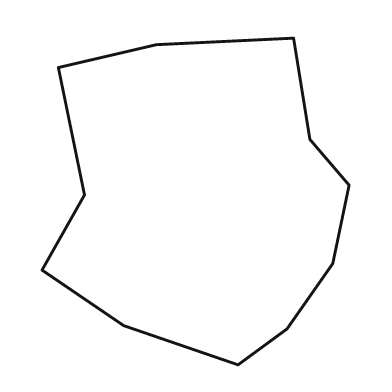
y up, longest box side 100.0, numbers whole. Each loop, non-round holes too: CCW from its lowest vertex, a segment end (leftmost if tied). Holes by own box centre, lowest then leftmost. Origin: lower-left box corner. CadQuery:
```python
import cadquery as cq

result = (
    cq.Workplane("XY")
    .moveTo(60.0, 0.0)
    .lineTo(75.0, 11.0)
    .lineTo(89.0, 31.0)
    .lineTo(94.0, 55.0)
    .lineTo(82.0, 69.0)
    .lineTo(77.0, 100.0)
    .lineTo(35.0, 98.0)
    .lineTo(5.0, 91.0)
    .lineTo(13.0, 52.0)
    .lineTo(0.0, 29.0)
    .lineTo(25.0, 12.0)
    .close()
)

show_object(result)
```